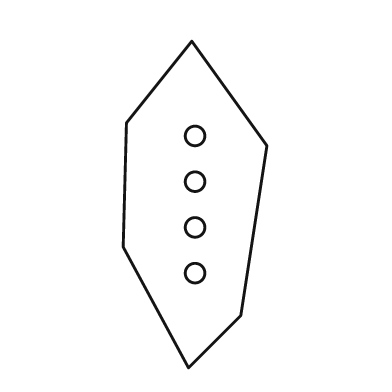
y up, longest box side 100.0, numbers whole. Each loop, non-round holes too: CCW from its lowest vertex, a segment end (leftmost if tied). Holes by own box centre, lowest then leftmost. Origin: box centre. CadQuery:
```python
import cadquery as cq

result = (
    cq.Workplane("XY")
    .moveTo(-2.0, -50.0)
    .lineTo(14.0, -34.0)
    .lineTo(22.0, 18.0)
    .lineTo(-1.0, 50.0)
    .lineTo(-21.0, 25.0)
    .lineTo(-22.0, -13.0)
    .close()
    .moveTo(0.0, -21.0)
    .circle(3.0)
    .moveTo(0.0, -7.0)
    .circle(3.0)
    .moveTo(0.0, 7.0)
    .circle(3.0)
    .moveTo(0.0, 21.0)
    .circle(3.0)
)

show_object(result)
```